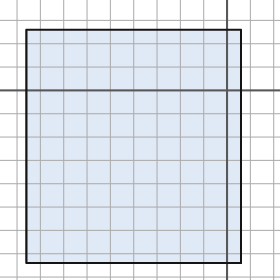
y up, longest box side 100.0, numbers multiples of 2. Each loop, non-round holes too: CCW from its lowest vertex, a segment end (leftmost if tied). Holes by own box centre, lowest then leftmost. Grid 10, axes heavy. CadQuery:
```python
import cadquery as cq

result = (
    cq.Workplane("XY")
    .moveTo(-86.0, -74.0)
    .lineTo(6.0, -74.0)
    .lineTo(6.0, 26.0)
    .lineTo(-86.0, 26.0)
    .close()
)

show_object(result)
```